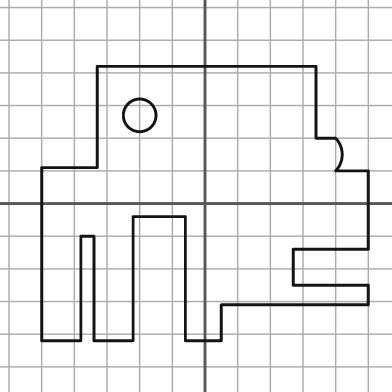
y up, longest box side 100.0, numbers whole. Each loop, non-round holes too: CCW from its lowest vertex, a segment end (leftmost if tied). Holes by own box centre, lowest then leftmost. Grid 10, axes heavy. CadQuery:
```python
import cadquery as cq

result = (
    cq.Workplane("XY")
    .moveTo(-50.0, -42.0)
    .lineTo(-38.0, -42.0)
    .lineTo(-38.0, -10.0)
    .lineTo(-34.0, -10.0)
    .lineTo(-34.0, -42.0)
    .lineTo(-22.0, -42.0)
    .lineTo(-22.0, -4.0)
    .lineTo(-6.0, -4.0)
    .lineTo(-6.0, -42.0)
    .lineTo(5.0, -42.0)
    .lineTo(5.0, -31.0)
    .lineTo(50.0, -31.0)
    .lineTo(50.0, -25.0)
    .lineTo(27.0, -25.0)
    .lineTo(27.0, -14.0)
    .lineTo(50.0, -14.0)
    .lineTo(50.0, 10.0)
    .lineTo(40.0, 10.0)
    .threePointArc((42.0, 15.0), (40.0, 20.0))
    .lineTo(34.0, 20.0)
    .lineTo(34.0, 42.0)
    .lineTo(-33.0, 42.0)
    .lineTo(-33.0, 11.0)
    .lineTo(-50.0, 11.0)
    .close()
    .moveTo(-20.0, 27.0)
    .circle(5.0)
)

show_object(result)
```